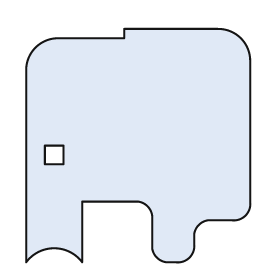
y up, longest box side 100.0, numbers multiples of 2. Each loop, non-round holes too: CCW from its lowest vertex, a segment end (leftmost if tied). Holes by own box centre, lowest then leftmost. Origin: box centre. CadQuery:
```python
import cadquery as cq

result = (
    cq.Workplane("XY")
    .moveTo(-48.0, -50.0)
    .threePointArc((-36.0, -44.0), (-24.0, -50.0))
    .lineTo(-24.0, -24.0)
    .lineTo(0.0, -24.0)
    .threePointArc((4.0, -26.0), (6.0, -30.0))
    .lineTo(6.0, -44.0)
    .threePointArc((8.0, -48.0), (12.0, -50.0))
    .lineTo(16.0, -50.0)
    .threePointArc((22.0, -48.0), (24.0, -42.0))
    .lineTo(24.0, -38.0)
    .threePointArc((26.0, -34.0), (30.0, -32.0))
    .lineTo(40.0, -32.0)
    .threePointArc((46.0, -30.0), (48.0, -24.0))
    .lineTo(48.0, 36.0)
    .threePointArc((44.0, 46.0), (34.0, 50.0))
    .lineTo(-6.0, 50.0)
    .lineTo(-6.0, 46.0)
    .lineTo(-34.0, 46.0)
    .threePointArc((-44.0, 42.0), (-48.0, 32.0))
    .close()
    .moveTo(-40.0, -8.0)
    .lineTo(-32.0, -8.0)
    .lineTo(-32.0, 0.0)
    .lineTo(-40.0, 0.0)
    .close()
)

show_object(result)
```